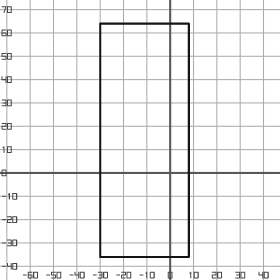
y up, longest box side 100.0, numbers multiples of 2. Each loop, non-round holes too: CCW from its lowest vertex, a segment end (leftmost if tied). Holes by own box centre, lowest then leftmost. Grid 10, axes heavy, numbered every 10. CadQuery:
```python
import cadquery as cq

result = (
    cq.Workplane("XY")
    .moveTo(-30.0, -36.0)
    .lineTo(8.0, -36.0)
    .lineTo(8.0, 64.0)
    .lineTo(-30.0, 64.0)
    .close()
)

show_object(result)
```